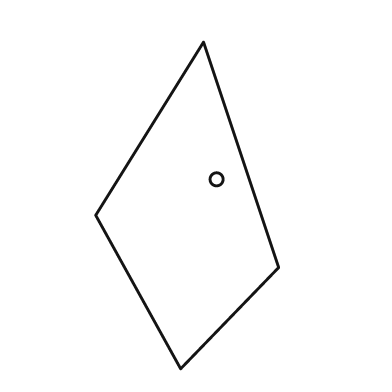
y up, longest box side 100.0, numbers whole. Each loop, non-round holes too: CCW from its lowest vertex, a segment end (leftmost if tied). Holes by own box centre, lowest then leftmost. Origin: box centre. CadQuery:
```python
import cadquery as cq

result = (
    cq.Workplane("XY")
    .moveTo(-2.0, -50.0)
    .lineTo(28.0, -19.0)
    .lineTo(5.0, 50.0)
    .lineTo(-28.0, -3.0)
    .close()
    .moveTo(9.0, 8.0)
    .circle(2.0)
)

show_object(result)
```